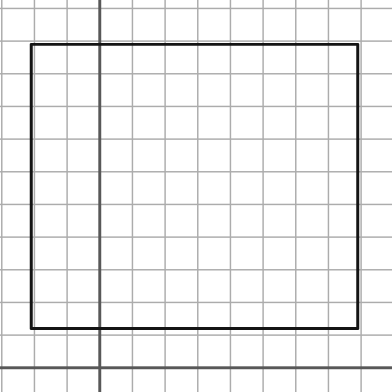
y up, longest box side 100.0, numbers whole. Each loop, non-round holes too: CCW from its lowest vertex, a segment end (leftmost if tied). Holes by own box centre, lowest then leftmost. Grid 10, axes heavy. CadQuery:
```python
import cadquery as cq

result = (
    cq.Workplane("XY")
    .moveTo(-21.0, 12.0)
    .lineTo(79.0, 12.0)
    .lineTo(79.0, 99.0)
    .lineTo(-21.0, 99.0)
    .close()
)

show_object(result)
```